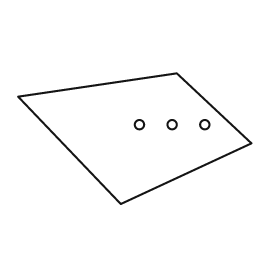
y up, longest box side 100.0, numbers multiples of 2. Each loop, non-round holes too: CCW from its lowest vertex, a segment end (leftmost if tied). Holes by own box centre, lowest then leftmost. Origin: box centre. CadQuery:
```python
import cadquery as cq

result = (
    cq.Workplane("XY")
    .moveTo(-6.0, -28.0)
    .lineTo(50.0, -2.0)
    .lineTo(18.0, 28.0)
    .lineTo(-50.0, 18.0)
    .close()
    .moveTo(2.0, 6.0)
    .circle(2.0)
    .moveTo(16.0, 6.0)
    .circle(2.0)
    .moveTo(30.0, 6.0)
    .circle(2.0)
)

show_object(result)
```